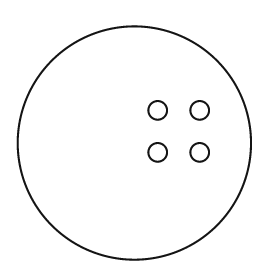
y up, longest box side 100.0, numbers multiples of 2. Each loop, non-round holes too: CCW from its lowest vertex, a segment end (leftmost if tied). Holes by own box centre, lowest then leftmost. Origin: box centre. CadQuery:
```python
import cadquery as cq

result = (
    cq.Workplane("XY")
    .moveTo(0.0, 0.0)
    .circle(50.0)
    .moveTo(10.0, -4.0)
    .circle(4.0)
    .moveTo(28.0, -4.0)
    .circle(4.0)
    .moveTo(10.0, 14.0)
    .circle(4.0)
    .moveTo(28.0, 14.0)
    .circle(4.0)
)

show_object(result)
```